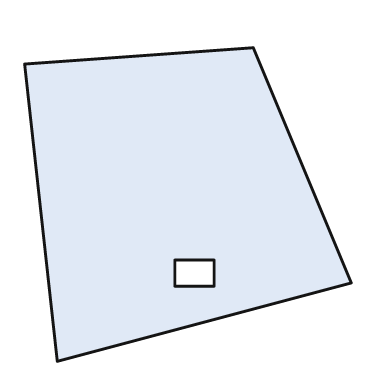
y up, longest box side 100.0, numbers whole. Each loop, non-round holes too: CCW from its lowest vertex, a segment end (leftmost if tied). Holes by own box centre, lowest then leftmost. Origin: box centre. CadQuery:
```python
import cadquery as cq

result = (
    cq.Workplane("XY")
    .moveTo(-40.0, -48.0)
    .lineTo(50.0, -24.0)
    .lineTo(20.0, 48.0)
    .lineTo(-50.0, 43.0)
    .close()
    .moveTo(-4.0, -25.0)
    .lineTo(8.0, -25.0)
    .lineTo(8.0, -17.0)
    .lineTo(-4.0, -17.0)
    .close()
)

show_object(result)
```